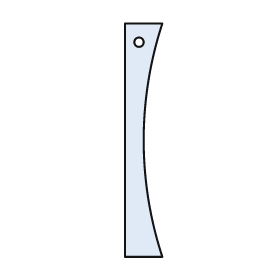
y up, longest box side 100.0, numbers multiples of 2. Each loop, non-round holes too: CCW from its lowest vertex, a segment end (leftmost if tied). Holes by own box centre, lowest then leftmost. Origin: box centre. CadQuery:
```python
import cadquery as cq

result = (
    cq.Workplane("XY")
    .moveTo(-8.0, -50.0)
    .lineTo(8.0, -50.0)
    .threePointArc((0.0, 0.0), (8.0, 50.0))
    .lineTo(-8.0, 50.0)
    .close()
    .moveTo(-2.0, 42.0)
    .circle(2.0)
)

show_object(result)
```